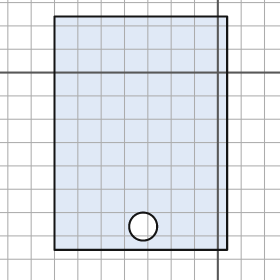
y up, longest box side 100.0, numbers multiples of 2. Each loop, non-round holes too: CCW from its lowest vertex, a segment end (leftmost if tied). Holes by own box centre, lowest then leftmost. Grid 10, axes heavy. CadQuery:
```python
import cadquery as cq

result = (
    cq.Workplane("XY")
    .moveTo(-70.0, -76.0)
    .lineTo(4.0, -76.0)
    .lineTo(4.0, 24.0)
    .lineTo(-70.0, 24.0)
    .close()
    .moveTo(-32.0, -66.0)
    .circle(6.0)
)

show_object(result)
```